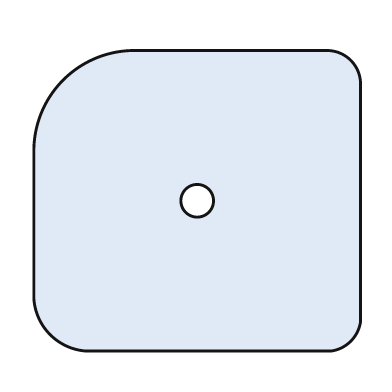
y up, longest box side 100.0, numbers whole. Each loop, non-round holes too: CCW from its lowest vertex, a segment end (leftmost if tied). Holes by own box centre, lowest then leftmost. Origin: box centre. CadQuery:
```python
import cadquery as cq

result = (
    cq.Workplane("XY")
    .moveTo(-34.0, -46.0)
    .lineTo(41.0, -46.0)
    .threePointArc((47.0, -43.0), (50.0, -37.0))
    .lineTo(50.0, 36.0)
    .threePointArc((47.0, 43.0), (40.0, 46.0))
    .lineTo(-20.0, 46.0)
    .threePointArc((-41.0, 37.0), (-50.0, 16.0))
    .lineTo(-50.0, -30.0)
    .threePointArc((-45.0, -41.0), (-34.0, -46.0))
    .close()
    .moveTo(0.0, 0.0)
    .circle(5.0)
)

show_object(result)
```